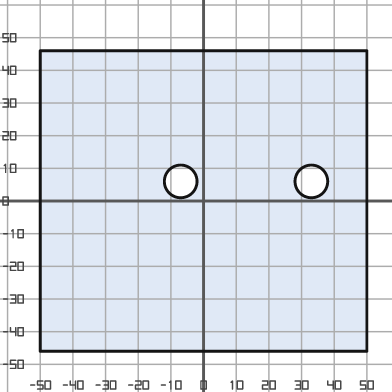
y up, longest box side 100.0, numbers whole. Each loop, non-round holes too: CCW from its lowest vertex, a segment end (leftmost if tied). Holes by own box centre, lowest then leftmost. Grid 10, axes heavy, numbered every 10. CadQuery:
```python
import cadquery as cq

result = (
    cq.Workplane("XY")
    .moveTo(-50.0, -46.0)
    .lineTo(50.0, -46.0)
    .lineTo(50.0, 46.0)
    .lineTo(-50.0, 46.0)
    .close()
    .moveTo(-7.0, 6.0)
    .circle(5.0)
    .moveTo(33.0, 6.0)
    .circle(5.0)
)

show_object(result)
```